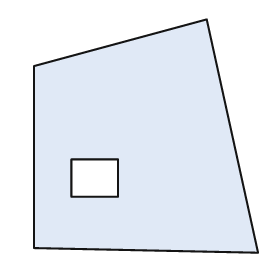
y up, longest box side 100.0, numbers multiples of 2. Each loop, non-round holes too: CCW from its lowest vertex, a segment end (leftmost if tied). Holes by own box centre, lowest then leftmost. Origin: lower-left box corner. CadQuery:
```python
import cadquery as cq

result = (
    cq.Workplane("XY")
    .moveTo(96.0, 0.0)
    .lineTo(74.0, 100.0)
    .lineTo(0.0, 80.0)
    .lineTo(0.0, 2.0)
    .close()
    .moveTo(16.0, 24.0)
    .lineTo(36.0, 24.0)
    .lineTo(36.0, 40.0)
    .lineTo(16.0, 40.0)
    .close()
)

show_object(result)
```